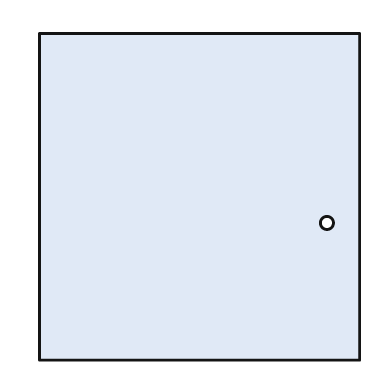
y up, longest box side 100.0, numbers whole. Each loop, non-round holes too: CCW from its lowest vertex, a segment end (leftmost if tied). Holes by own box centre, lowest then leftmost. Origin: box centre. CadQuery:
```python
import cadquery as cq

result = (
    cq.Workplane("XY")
    .moveTo(-49.0, -50.0)
    .lineTo(49.0, -50.0)
    .lineTo(49.0, 50.0)
    .lineTo(-49.0, 50.0)
    .close()
    .moveTo(39.0, -8.0)
    .circle(2.0)
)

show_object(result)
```